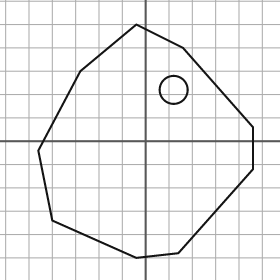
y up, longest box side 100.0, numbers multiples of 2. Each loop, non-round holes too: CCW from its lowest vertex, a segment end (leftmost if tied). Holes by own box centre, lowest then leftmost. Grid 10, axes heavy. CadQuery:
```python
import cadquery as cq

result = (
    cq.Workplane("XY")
    .moveTo(-4.0, -50.0)
    .lineTo(14.0, -48.0)
    .lineTo(46.0, -12.0)
    .lineTo(46.0, 6.0)
    .lineTo(16.0, 40.0)
    .lineTo(-4.0, 50.0)
    .lineTo(-28.0, 30.0)
    .lineTo(-46.0, -4.0)
    .lineTo(-40.0, -34.0)
    .close()
    .moveTo(12.0, 22.0)
    .circle(6.0)
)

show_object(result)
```